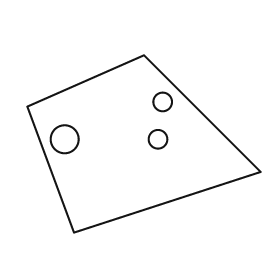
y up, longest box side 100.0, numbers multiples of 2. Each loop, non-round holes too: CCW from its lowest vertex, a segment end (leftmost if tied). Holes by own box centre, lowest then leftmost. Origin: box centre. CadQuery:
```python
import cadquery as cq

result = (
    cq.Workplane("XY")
    .moveTo(-30.0, -38.0)
    .lineTo(50.0, -12.0)
    .lineTo(0.0, 38.0)
    .lineTo(-50.0, 16.0)
    .close()
    .moveTo(-34.0, 2.0)
    .circle(6.0)
    .moveTo(6.0, 2.0)
    .circle(4.0)
    .moveTo(8.0, 18.0)
    .circle(4.0)
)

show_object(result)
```